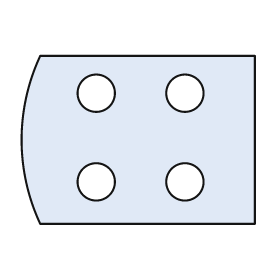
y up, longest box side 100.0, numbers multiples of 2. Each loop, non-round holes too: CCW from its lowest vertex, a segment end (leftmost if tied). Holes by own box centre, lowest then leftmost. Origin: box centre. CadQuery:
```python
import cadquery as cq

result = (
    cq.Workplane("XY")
    .moveTo(-42.0, -36.0)
    .lineTo(50.0, -36.0)
    .lineTo(50.0, 36.0)
    .lineTo(-42.0, 36.0)
    .threePointArc((-50.0, 0.0), (-42.0, -36.0))
    .close()
    .moveTo(-18.0, -18.0)
    .circle(8.0)
    .moveTo(20.0, -18.0)
    .circle(8.0)
    .moveTo(-18.0, 20.0)
    .circle(8.0)
    .moveTo(20.0, 20.0)
    .circle(8.0)
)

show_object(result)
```